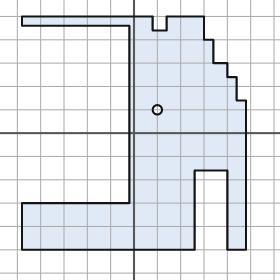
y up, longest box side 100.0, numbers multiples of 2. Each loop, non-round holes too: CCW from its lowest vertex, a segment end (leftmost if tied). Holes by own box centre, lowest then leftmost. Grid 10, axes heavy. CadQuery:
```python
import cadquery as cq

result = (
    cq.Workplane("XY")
    .moveTo(-48.0, -50.0)
    .lineTo(26.0, -50.0)
    .lineTo(26.0, -16.0)
    .lineTo(40.0, -16.0)
    .lineTo(40.0, -50.0)
    .lineTo(48.0, -50.0)
    .lineTo(48.0, 14.0)
    .lineTo(44.0, 14.0)
    .lineTo(44.0, 24.0)
    .lineTo(40.0, 24.0)
    .lineTo(40.0, 30.0)
    .lineTo(34.0, 30.0)
    .lineTo(34.0, 40.0)
    .lineTo(30.0, 40.0)
    .lineTo(30.0, 50.0)
    .lineTo(14.0, 50.0)
    .lineTo(14.0, 44.0)
    .lineTo(8.0, 44.0)
    .lineTo(8.0, 50.0)
    .lineTo(-48.0, 50.0)
    .lineTo(-48.0, 46.0)
    .lineTo(-2.0, 46.0)
    .lineTo(-2.0, -30.0)
    .lineTo(-48.0, -30.0)
    .close()
    .moveTo(10.0, 10.0)
    .circle(2.0)
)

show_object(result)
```